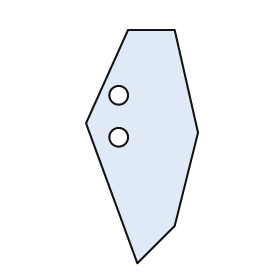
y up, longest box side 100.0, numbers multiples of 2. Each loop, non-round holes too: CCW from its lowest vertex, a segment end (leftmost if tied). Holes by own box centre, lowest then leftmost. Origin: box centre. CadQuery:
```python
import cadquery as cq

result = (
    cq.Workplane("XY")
    .moveTo(-2.0, -50.0)
    .lineTo(14.0, -34.0)
    .lineTo(24.0, 6.0)
    .lineTo(14.0, 50.0)
    .lineTo(-6.0, 50.0)
    .lineTo(-24.0, 10.0)
    .close()
    .moveTo(-10.0, 4.0)
    .circle(4.0)
    .moveTo(-10.0, 22.0)
    .circle(4.0)
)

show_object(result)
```